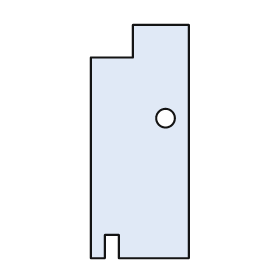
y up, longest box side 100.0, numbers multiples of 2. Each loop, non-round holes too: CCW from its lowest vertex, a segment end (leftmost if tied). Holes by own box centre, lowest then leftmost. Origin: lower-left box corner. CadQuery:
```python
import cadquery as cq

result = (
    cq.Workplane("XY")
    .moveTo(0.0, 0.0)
    .lineTo(6.0, 0.0)
    .lineTo(6.0, 10.0)
    .lineTo(12.0, 10.0)
    .lineTo(12.0, 0.0)
    .lineTo(42.0, 0.0)
    .lineTo(42.0, 100.0)
    .lineTo(18.0, 100.0)
    .lineTo(18.0, 86.0)
    .lineTo(0.0, 86.0)
    .close()
    .moveTo(32.0, 60.0)
    .circle(4.0)
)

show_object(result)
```